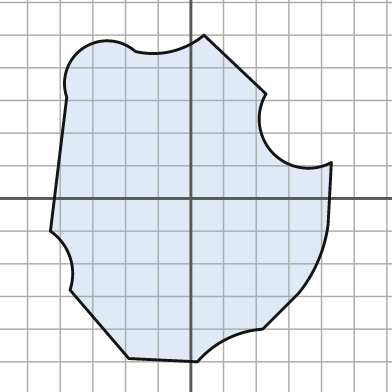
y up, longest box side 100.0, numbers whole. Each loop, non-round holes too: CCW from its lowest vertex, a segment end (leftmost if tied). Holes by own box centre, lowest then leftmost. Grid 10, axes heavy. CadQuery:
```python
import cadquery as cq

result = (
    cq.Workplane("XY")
    .moveTo(2.0, -50.0)
    .threePointArc((11.0, -43.0), (22.0, -40.0))
    .lineTo(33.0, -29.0)
    .threePointArc((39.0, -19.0), (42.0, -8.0))
    .lineTo(43.0, 11.0)
    .threePointArc((25.0, 14.0), (23.0, 32.0))
    .lineTo(4.0, 50.0)
    .threePointArc((-6.0, 45.0), (-17.0, 45.0))
    .threePointArc((-33.0, 46.0), (-38.0, 31.0))
    .lineTo(-43.0, -10.0)
    .threePointArc((-37.0, -18.0), (-37.0, -28.0))
    .lineTo(-19.0, -49.0)
    .close()
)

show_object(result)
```